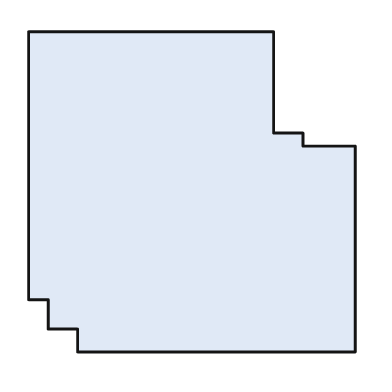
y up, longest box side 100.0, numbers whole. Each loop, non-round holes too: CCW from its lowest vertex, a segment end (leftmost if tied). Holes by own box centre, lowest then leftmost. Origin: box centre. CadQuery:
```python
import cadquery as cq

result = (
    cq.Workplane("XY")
    .moveTo(-35.0, -49.0)
    .lineTo(50.0, -49.0)
    .lineTo(50.0, 14.0)
    .lineTo(34.0, 14.0)
    .lineTo(34.0, 18.0)
    .lineTo(25.0, 18.0)
    .lineTo(25.0, 49.0)
    .lineTo(-50.0, 49.0)
    .lineTo(-50.0, -33.0)
    .lineTo(-44.0, -33.0)
    .lineTo(-44.0, -42.0)
    .lineTo(-35.0, -42.0)
    .close()
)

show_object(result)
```